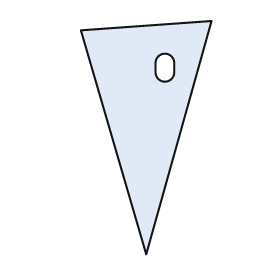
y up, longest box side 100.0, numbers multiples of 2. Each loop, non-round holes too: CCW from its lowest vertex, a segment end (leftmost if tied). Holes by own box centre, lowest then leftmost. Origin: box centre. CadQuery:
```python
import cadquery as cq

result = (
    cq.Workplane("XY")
    .moveTo(0.0, -50.0)
    .lineTo(28.0, 50.0)
    .lineTo(-28.0, 46.0)
    .close()
    .moveTo(4.0, 28.0)
    .threePointArc((8.0, 24.0), (12.0, 28.0))
    .lineTo(12.0, 32.0)
    .threePointArc((8.0, 36.0), (4.0, 32.0))
    .close()
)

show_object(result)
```